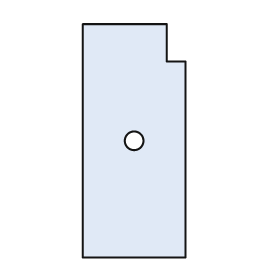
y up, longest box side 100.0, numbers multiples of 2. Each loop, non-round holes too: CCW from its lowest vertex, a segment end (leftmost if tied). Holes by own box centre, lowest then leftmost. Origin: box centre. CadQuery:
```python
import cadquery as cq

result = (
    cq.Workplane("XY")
    .moveTo(-22.0, -50.0)
    .lineTo(22.0, -50.0)
    .lineTo(22.0, 34.0)
    .lineTo(14.0, 34.0)
    .lineTo(14.0, 50.0)
    .lineTo(-22.0, 50.0)
    .close()
    .moveTo(0.0, 0.0)
    .circle(4.0)
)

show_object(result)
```